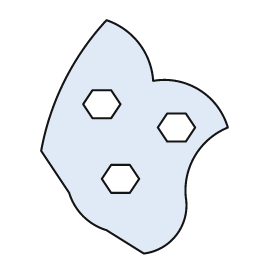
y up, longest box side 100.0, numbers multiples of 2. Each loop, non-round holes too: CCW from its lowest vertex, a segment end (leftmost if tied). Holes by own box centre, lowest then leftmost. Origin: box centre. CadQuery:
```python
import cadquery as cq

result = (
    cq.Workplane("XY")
    .moveTo(4.0, -50.0)
    .threePointArc((18.0, -42.0), (22.0, -26.0))
    .threePointArc((26.0, -8.0), (40.0, 4.0))
    .threePointArc((28.0, 20.0), (8.0, 24.0))
    .threePointArc((2.0, 40.0), (-12.0, 50.0))
    .threePointArc((-30.0, 24.0), (-40.0, -6.0))
    .lineTo(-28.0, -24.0)
    .threePointArc((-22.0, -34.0), (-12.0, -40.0))
    .close()
    .moveTo(-10.0, -24.0)
    .lineTo(-2.0, -24.0)
    .lineTo(2.0, -18.0)
    .lineTo(-2.0, -12.0)
    .lineTo(-10.0, -12.0)
    .lineTo(-14.0, -18.0)
    .close()
    .moveTo(14.0, -2.0)
    .lineTo(22.0, -2.0)
    .lineTo(26.0, 4.0)
    .lineTo(22.0, 10.0)
    .lineTo(14.0, 10.0)
    .lineTo(10.0, 4.0)
    .close()
    .moveTo(-18.0, 8.0)
    .lineTo(-10.0, 8.0)
    .lineTo(-6.0, 14.0)
    .lineTo(-10.0, 20.0)
    .lineTo(-18.0, 20.0)
    .lineTo(-22.0, 14.0)
    .close()
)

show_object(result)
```